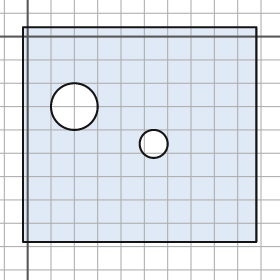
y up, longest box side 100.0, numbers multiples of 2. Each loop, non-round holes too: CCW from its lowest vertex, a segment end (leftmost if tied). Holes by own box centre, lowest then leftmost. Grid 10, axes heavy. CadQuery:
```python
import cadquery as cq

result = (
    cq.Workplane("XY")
    .moveTo(-2.0, -88.0)
    .lineTo(98.0, -88.0)
    .lineTo(98.0, 4.0)
    .lineTo(-2.0, 4.0)
    .close()
    .moveTo(54.0, -46.0)
    .circle(6.0)
    .moveTo(20.0, -30.0)
    .circle(10.0)
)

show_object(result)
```